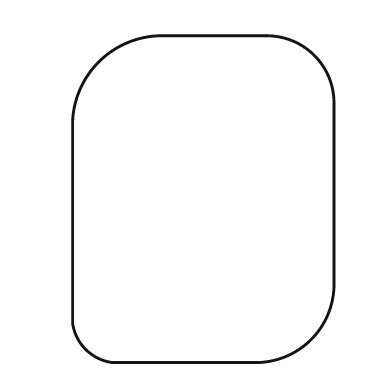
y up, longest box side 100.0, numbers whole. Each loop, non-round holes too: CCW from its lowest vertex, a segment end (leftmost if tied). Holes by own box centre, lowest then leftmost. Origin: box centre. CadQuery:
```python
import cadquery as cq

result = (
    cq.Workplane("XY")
    .moveTo(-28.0, -50.0)
    .lineTo(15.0, -50.0)
    .threePointArc((33.0, -43.0), (40.0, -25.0))
    .lineTo(40.0, 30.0)
    .threePointArc((34.0, 44.0), (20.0, 50.0))
    .lineTo(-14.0, 50.0)
    .threePointArc((-32.0, 42.0), (-40.0, 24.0))
    .lineTo(-40.0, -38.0)
    .threePointArc((-36.0, -46.0), (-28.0, -50.0))
    .close()
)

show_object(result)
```